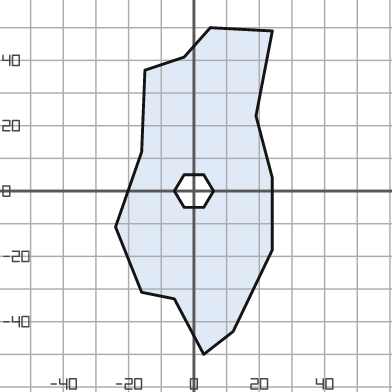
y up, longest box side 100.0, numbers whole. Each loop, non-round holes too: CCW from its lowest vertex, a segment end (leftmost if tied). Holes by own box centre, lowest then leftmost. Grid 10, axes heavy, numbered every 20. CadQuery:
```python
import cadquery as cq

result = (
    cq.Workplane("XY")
    .moveTo(3.0, -50.0)
    .lineTo(12.0, -43.0)
    .lineTo(24.0, -18.0)
    .lineTo(24.0, 4.0)
    .lineTo(19.0, 23.0)
    .lineTo(24.0, 49.0)
    .lineTo(5.0, 50.0)
    .lineTo(-3.0, 41.0)
    .lineTo(-15.0, 37.0)
    .lineTo(-16.0, 12.0)
    .lineTo(-24.0, -11.0)
    .lineTo(-16.0, -31.0)
    .lineTo(-6.0, -33.0)
    .close()
    .moveTo(-3.0, -5.0)
    .lineTo(3.0, -5.0)
    .lineTo(6.0, 0.0)
    .lineTo(3.0, 5.0)
    .lineTo(-3.0, 5.0)
    .lineTo(-6.0, 0.0)
    .close()
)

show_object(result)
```